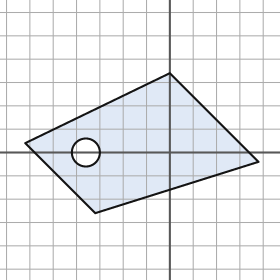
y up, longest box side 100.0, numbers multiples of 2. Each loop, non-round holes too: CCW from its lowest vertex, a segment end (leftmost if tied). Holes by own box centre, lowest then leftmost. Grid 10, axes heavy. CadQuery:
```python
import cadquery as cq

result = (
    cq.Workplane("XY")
    .moveTo(-32.0, -26.0)
    .lineTo(38.0, -4.0)
    .lineTo(0.0, 34.0)
    .lineTo(-62.0, 4.0)
    .close()
    .moveTo(-36.0, 0.0)
    .circle(6.0)
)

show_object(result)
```